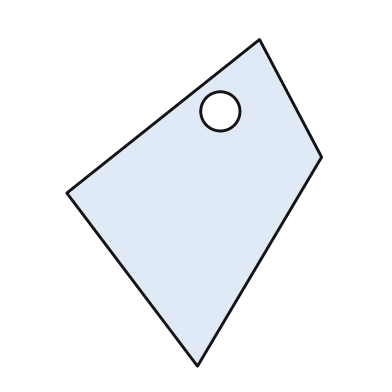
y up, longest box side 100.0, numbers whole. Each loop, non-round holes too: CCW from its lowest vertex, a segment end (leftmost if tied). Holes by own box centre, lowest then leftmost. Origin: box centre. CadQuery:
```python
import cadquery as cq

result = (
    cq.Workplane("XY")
    .moveTo(1.0, -50.0)
    .lineTo(39.0, 14.0)
    .lineTo(20.0, 50.0)
    .lineTo(-39.0, 3.0)
    .close()
    .moveTo(8.0, 28.0)
    .circle(6.0)
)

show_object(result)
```